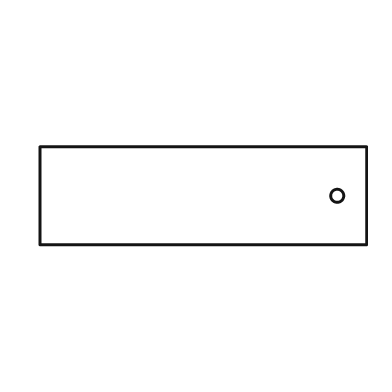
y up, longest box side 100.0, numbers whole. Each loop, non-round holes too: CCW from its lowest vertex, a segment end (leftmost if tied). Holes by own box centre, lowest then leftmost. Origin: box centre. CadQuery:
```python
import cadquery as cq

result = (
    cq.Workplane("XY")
    .moveTo(-50.0, -15.0)
    .lineTo(50.0, -15.0)
    .lineTo(50.0, 15.0)
    .lineTo(-50.0, 15.0)
    .close()
    .moveTo(41.0, 0.0)
    .circle(2.0)
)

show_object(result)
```